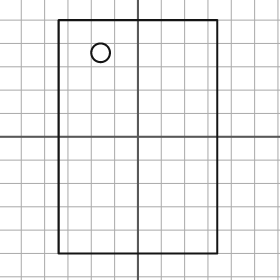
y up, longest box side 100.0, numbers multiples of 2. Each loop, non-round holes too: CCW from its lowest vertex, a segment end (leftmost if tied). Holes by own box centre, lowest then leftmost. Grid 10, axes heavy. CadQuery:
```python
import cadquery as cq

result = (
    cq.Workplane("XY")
    .moveTo(-34.0, -50.0)
    .lineTo(34.0, -50.0)
    .lineTo(34.0, 50.0)
    .lineTo(-34.0, 50.0)
    .close()
    .moveTo(-16.0, 36.0)
    .circle(4.0)
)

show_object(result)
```